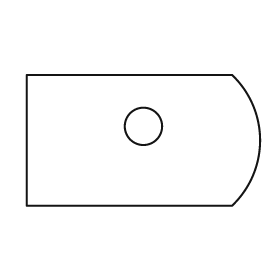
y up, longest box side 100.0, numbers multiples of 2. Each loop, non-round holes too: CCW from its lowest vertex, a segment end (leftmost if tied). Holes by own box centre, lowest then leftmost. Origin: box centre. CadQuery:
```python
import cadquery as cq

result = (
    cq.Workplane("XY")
    .moveTo(-50.0, -28.0)
    .lineTo(38.0, -28.0)
    .threePointArc((50.0, 0.0), (38.0, 28.0))
    .lineTo(-50.0, 28.0)
    .close()
    .moveTo(0.0, 6.0)
    .circle(8.0)
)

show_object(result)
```